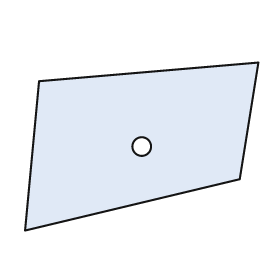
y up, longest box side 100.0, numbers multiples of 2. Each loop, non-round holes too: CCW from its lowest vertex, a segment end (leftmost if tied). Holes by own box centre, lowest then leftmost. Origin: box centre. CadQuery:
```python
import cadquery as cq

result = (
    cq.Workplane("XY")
    .moveTo(-50.0, -36.0)
    .lineTo(42.0, -14.0)
    .lineTo(50.0, 36.0)
    .lineTo(-44.0, 28.0)
    .close()
    .moveTo(0.0, 0.0)
    .circle(4.0)
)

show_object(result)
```